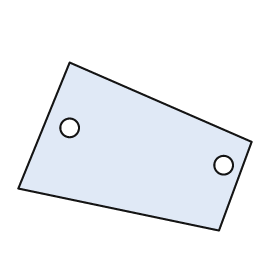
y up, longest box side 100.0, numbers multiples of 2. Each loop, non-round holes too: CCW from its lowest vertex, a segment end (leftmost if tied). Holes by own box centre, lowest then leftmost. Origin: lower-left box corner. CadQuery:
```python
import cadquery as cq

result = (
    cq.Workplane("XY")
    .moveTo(86.0, 0.0)
    .lineTo(100.0, 38.0)
    .lineTo(22.0, 72.0)
    .lineTo(0.0, 18.0)
    .close()
    .moveTo(88.0, 28.0)
    .circle(4.0)
    .moveTo(22.0, 44.0)
    .circle(4.0)
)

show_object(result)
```